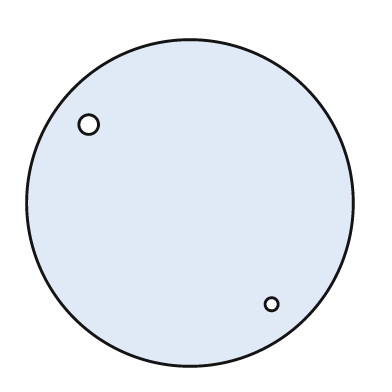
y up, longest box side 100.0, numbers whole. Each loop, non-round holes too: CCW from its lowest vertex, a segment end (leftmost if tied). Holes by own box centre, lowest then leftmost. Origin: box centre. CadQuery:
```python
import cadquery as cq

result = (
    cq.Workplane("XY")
    .moveTo(0.0, 0.0)
    .circle(50.0)
    .moveTo(25.0, -31.0)
    .circle(2.0)
    .moveTo(-31.0, 24.0)
    .circle(3.0)
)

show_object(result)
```